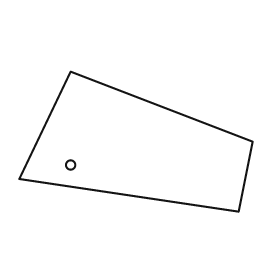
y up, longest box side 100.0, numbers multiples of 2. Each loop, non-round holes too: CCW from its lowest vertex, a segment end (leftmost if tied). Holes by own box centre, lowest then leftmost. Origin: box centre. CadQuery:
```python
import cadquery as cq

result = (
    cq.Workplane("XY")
    .moveTo(44.0, -30.0)
    .lineTo(50.0, 0.0)
    .lineTo(-28.0, 30.0)
    .lineTo(-50.0, -16.0)
    .close()
    .moveTo(-28.0, -10.0)
    .circle(2.0)
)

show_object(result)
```